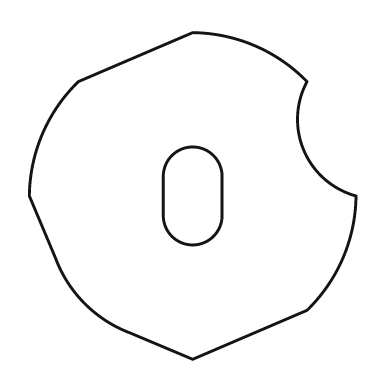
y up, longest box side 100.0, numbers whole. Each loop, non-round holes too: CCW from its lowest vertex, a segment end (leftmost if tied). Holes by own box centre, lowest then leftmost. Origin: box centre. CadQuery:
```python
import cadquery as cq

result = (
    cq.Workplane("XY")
    .moveTo(0.0, -50.0)
    .lineTo(35.0, -35.0)
    .threePointArc((46.0, -19.0), (50.0, 0.0))
    .threePointArc((34.0, 14.0), (35.0, 35.0))
    .threePointArc((19.0, 46.0), (0.0, 50.0))
    .lineTo(-35.0, 35.0)
    .threePointArc((-46.0, 19.0), (-50.0, 0.0))
    .lineTo(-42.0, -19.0)
    .threePointArc((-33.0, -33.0), (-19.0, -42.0))
    .close()
    .moveTo(-9.0, -6.0)
    .threePointArc((0.0, -15.0), (9.0, -6.0))
    .lineTo(9.0, 6.0)
    .threePointArc((0.0, 15.0), (-9.0, 6.0))
    .close()
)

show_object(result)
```